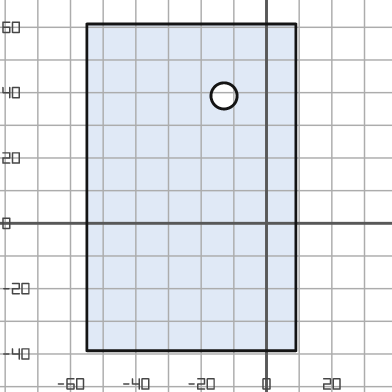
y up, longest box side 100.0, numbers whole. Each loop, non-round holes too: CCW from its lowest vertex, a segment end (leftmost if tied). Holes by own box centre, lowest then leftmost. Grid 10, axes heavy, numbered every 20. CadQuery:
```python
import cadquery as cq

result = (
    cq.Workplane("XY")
    .moveTo(-55.0, -39.0)
    .lineTo(9.0, -39.0)
    .lineTo(9.0, 61.0)
    .lineTo(-55.0, 61.0)
    .close()
    .moveTo(-13.0, 39.0)
    .circle(4.0)
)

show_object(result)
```